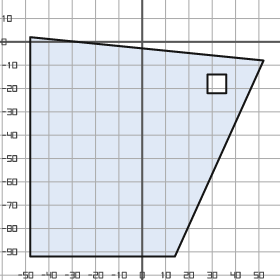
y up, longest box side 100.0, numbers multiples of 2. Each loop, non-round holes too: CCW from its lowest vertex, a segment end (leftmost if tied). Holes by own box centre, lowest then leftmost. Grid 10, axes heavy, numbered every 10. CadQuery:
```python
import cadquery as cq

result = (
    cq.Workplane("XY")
    .moveTo(-48.0, -92.0)
    .lineTo(14.0, -92.0)
    .lineTo(52.0, -8.0)
    .lineTo(-48.0, 2.0)
    .close()
    .moveTo(28.0, -22.0)
    .lineTo(36.0, -22.0)
    .lineTo(36.0, -14.0)
    .lineTo(28.0, -14.0)
    .close()
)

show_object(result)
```